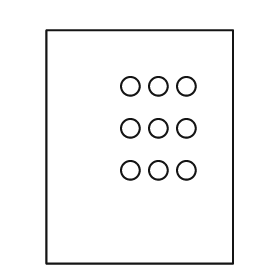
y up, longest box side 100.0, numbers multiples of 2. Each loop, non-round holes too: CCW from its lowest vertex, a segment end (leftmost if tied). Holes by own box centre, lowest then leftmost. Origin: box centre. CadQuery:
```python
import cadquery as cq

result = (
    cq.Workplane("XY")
    .moveTo(-40.0, -50.0)
    .lineTo(40.0, -50.0)
    .lineTo(40.0, 50.0)
    .lineTo(-40.0, 50.0)
    .close()
    .moveTo(-4.0, -10.0)
    .circle(4.0)
    .moveTo(8.0, -10.0)
    .circle(4.0)
    .moveTo(20.0, -10.0)
    .circle(4.0)
    .moveTo(-4.0, 8.0)
    .circle(4.0)
    .moveTo(8.0, 8.0)
    .circle(4.0)
    .moveTo(20.0, 8.0)
    .circle(4.0)
    .moveTo(-4.0, 26.0)
    .circle(4.0)
    .moveTo(8.0, 26.0)
    .circle(4.0)
    .moveTo(20.0, 26.0)
    .circle(4.0)
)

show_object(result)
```